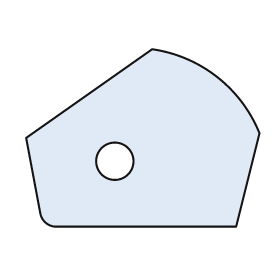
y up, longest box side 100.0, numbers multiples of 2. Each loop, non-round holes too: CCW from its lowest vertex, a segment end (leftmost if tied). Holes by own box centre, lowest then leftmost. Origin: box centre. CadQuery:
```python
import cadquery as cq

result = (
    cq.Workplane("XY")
    .moveTo(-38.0, -38.0)
    .lineTo(40.0, -38.0)
    .lineTo(50.0, 2.0)
    .threePointArc((32.0, 26.0), (4.0, 38.0))
    .lineTo(-50.0, 0.0)
    .lineTo(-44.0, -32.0)
    .threePointArc((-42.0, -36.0), (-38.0, -38.0))
    .close()
    .moveTo(-12.0, -10.0)
    .circle(8.0)
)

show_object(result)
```